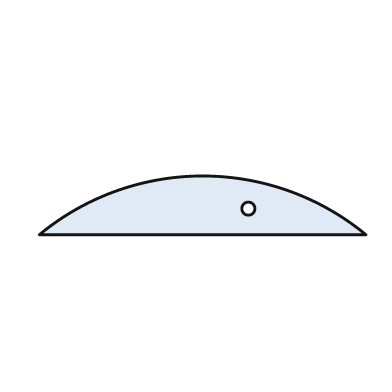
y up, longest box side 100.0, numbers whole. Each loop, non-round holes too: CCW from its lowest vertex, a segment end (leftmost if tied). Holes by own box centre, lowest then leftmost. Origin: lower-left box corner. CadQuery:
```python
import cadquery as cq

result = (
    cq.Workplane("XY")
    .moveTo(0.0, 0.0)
    .lineTo(100.0, 0.0)
    .threePointArc((50.0, 18.0), (0.0, 0.0))
    .close()
    .moveTo(64.0, 8.0)
    .circle(2.0)
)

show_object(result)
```